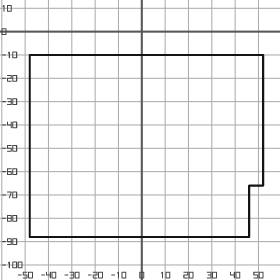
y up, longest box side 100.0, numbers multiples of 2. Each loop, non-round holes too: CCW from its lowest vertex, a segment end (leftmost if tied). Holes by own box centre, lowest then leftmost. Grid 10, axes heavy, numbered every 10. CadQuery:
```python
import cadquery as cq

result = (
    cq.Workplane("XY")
    .moveTo(-48.0, -88.0)
    .lineTo(46.0, -88.0)
    .lineTo(46.0, -66.0)
    .lineTo(52.0, -66.0)
    .lineTo(52.0, -10.0)
    .lineTo(-48.0, -10.0)
    .close()
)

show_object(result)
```